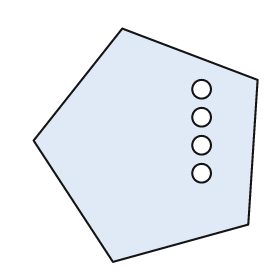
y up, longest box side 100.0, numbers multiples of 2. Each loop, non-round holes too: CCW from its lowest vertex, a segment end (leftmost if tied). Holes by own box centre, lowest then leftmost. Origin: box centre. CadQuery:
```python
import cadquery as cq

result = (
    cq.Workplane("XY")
    .moveTo(-14.0, -50.0)
    .lineTo(44.0, -34.0)
    .lineTo(48.0, 28.0)
    .lineTo(-10.0, 50.0)
    .lineTo(-48.0, 2.0)
    .close()
    .moveTo(24.0, -12.0)
    .circle(4.0)
    .moveTo(24.0, 0.0)
    .circle(4.0)
    .moveTo(24.0, 12.0)
    .circle(4.0)
    .moveTo(24.0, 24.0)
    .circle(4.0)
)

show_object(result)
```